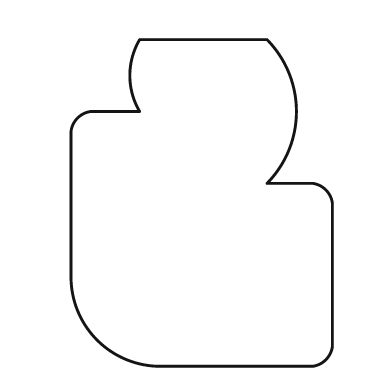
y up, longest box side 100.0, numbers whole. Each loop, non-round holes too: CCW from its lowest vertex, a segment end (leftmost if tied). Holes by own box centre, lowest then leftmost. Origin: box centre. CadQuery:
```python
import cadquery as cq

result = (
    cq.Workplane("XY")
    .moveTo(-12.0, -50.0)
    .lineTo(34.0, -50.0)
    .threePointArc((38.0, -48.0), (40.0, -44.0))
    .lineTo(40.0, 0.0)
    .threePointArc((38.0, 4.0), (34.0, 6.0))
    .lineTo(20.0, 6.0)
    .threePointArc((29.0, 28.0), (20.0, 50.0))
    .lineTo(-19.0, 50.0)
    .threePointArc((-22.0, 39.0), (-19.0, 28.0))
    .lineTo(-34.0, 28.0)
    .threePointArc((-38.0, 26.0), (-40.0, 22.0))
    .lineTo(-40.0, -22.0)
    .threePointArc((-32.0, -42.0), (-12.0, -50.0))
    .close()
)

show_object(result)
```